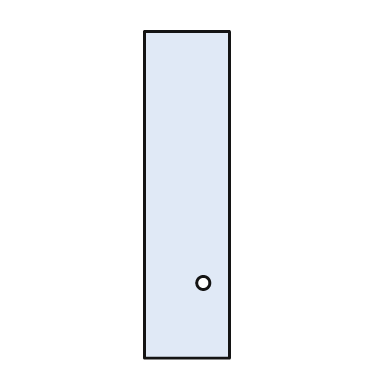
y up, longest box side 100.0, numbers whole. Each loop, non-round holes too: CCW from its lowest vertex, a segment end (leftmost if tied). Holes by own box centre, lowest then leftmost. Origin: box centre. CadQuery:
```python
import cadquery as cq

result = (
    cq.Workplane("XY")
    .moveTo(-13.0, -50.0)
    .lineTo(13.0, -50.0)
    .lineTo(13.0, 50.0)
    .lineTo(-13.0, 50.0)
    .close()
    .moveTo(5.0, -27.0)
    .circle(2.0)
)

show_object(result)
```